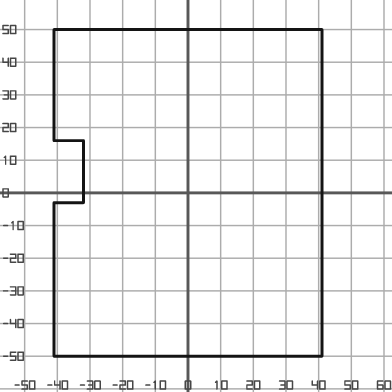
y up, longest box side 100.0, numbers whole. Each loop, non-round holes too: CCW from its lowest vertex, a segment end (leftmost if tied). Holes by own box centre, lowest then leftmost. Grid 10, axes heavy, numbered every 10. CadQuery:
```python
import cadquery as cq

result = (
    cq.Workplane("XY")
    .moveTo(-41.0, -50.0)
    .lineTo(41.0, -50.0)
    .lineTo(41.0, 50.0)
    .lineTo(-41.0, 50.0)
    .lineTo(-41.0, 16.0)
    .lineTo(-32.0, 16.0)
    .lineTo(-32.0, -3.0)
    .lineTo(-41.0, -3.0)
    .close()
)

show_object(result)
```